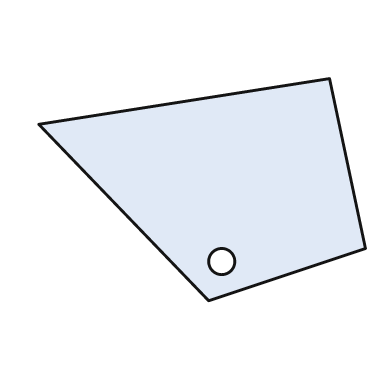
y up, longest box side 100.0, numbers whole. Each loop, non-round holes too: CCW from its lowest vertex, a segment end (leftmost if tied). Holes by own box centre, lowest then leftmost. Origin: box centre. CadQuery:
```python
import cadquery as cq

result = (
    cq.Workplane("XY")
    .moveTo(2.0, -34.0)
    .lineTo(50.0, -18.0)
    .lineTo(39.0, 34.0)
    .lineTo(-50.0, 20.0)
    .close()
    .moveTo(6.0, -22.0)
    .circle(4.0)
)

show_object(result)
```